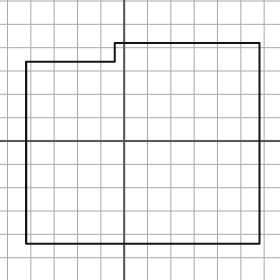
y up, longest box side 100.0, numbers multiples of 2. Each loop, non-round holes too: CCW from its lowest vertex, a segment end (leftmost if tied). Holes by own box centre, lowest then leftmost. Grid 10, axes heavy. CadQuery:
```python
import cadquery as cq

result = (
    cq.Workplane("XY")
    .moveTo(-42.0, -44.0)
    .lineTo(58.0, -44.0)
    .lineTo(58.0, 42.0)
    .lineTo(-4.0, 42.0)
    .lineTo(-4.0, 34.0)
    .lineTo(-42.0, 34.0)
    .close()
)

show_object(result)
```